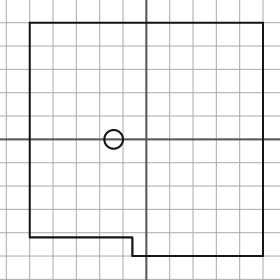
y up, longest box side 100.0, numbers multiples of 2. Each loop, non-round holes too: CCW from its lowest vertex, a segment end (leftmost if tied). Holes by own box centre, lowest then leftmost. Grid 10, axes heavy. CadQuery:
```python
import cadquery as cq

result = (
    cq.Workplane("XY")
    .moveTo(-6.0, -50.0)
    .lineTo(50.0, -50.0)
    .lineTo(50.0, 50.0)
    .lineTo(-50.0, 50.0)
    .lineTo(-50.0, -42.0)
    .lineTo(-6.0, -42.0)
    .close()
    .moveTo(-14.0, 0.0)
    .circle(4.0)
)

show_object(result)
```